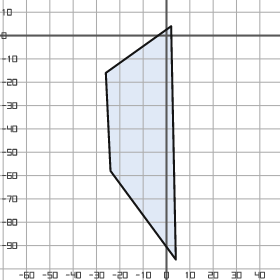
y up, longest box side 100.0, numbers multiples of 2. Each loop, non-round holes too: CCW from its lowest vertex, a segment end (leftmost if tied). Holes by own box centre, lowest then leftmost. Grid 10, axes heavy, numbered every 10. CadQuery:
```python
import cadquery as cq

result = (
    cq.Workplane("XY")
    .moveTo(4.0, -96.0)
    .lineTo(2.0, 4.0)
    .lineTo(-26.0, -16.0)
    .lineTo(-24.0, -58.0)
    .close()
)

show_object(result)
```